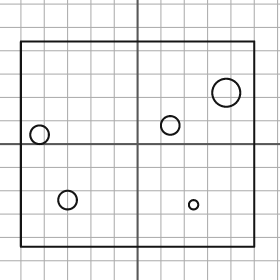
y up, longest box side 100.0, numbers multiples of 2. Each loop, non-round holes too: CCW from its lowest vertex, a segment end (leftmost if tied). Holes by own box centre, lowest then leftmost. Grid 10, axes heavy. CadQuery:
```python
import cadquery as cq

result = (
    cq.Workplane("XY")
    .moveTo(-50.0, -44.0)
    .lineTo(50.0, -44.0)
    .lineTo(50.0, 44.0)
    .lineTo(-50.0, 44.0)
    .close()
    .moveTo(24.0, -26.0)
    .circle(2.0)
    .moveTo(-30.0, -24.0)
    .circle(4.0)
    .moveTo(-42.0, 4.0)
    .circle(4.0)
    .moveTo(14.0, 8.0)
    .circle(4.0)
    .moveTo(38.0, 22.0)
    .circle(6.0)
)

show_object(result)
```